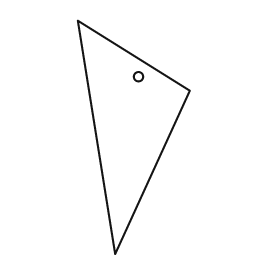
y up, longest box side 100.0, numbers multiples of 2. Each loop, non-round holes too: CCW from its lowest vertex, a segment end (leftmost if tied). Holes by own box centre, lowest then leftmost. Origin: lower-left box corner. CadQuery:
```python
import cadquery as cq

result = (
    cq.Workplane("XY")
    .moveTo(16.0, 0.0)
    .lineTo(48.0, 70.0)
    .lineTo(0.0, 100.0)
    .close()
    .moveTo(26.0, 76.0)
    .circle(2.0)
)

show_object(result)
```